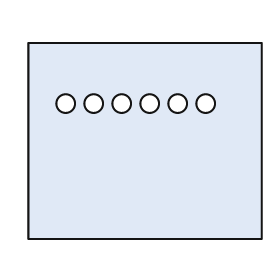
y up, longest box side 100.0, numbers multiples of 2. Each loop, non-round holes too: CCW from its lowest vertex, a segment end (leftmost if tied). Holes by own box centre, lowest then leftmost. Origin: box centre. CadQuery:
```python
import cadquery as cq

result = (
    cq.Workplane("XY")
    .moveTo(-50.0, -42.0)
    .lineTo(50.0, -42.0)
    .lineTo(50.0, 42.0)
    .lineTo(-50.0, 42.0)
    .close()
    .moveTo(-34.0, 16.0)
    .circle(4.0)
    .moveTo(-22.0, 16.0)
    .circle(4.0)
    .moveTo(-10.0, 16.0)
    .circle(4.0)
    .moveTo(2.0, 16.0)
    .circle(4.0)
    .moveTo(14.0, 16.0)
    .circle(4.0)
    .moveTo(26.0, 16.0)
    .circle(4.0)
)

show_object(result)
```